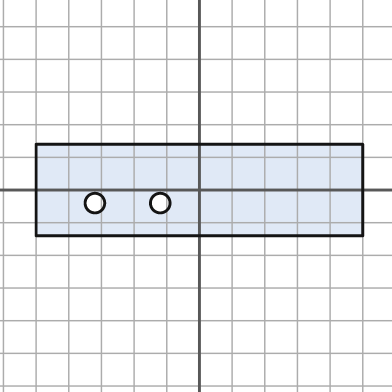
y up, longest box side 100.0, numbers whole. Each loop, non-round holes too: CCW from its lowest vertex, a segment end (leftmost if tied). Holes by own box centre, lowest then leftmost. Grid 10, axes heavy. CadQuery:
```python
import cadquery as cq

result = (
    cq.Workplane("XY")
    .moveTo(-50.0, -14.0)
    .lineTo(50.0, -14.0)
    .lineTo(50.0, 14.0)
    .lineTo(-50.0, 14.0)
    .close()
    .moveTo(-32.0, -4.0)
    .circle(3.0)
    .moveTo(-12.0, -4.0)
    .circle(3.0)
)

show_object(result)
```